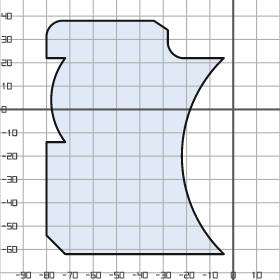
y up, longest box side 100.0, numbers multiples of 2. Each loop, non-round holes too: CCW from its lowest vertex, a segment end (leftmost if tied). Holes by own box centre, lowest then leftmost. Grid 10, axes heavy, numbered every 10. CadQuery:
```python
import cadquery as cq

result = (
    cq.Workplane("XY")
    .moveTo(-72.0, -62.0)
    .lineTo(-4.0, -62.0)
    .threePointArc((-22.0, -20.0), (-4.0, 22.0))
    .lineTo(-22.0, 22.0)
    .threePointArc((-26.0, 24.0), (-28.0, 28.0))
    .lineTo(-28.0, 34.0)
    .lineTo(-34.0, 38.0)
    .lineTo(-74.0, 38.0)
    .threePointArc((-78.0, 36.0), (-80.0, 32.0))
    .lineTo(-80.0, 22.0)
    .lineTo(-72.0, 22.0)
    .threePointArc((-78.0, 4.0), (-72.0, -14.0))
    .lineTo(-80.0, -14.0)
    .lineTo(-80.0, -54.0)
    .close()
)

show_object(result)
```